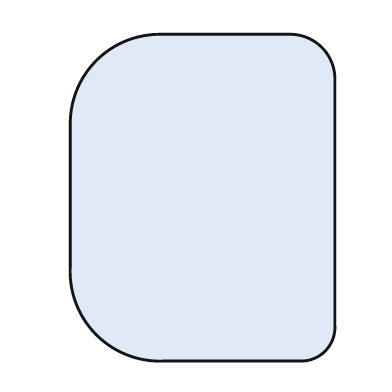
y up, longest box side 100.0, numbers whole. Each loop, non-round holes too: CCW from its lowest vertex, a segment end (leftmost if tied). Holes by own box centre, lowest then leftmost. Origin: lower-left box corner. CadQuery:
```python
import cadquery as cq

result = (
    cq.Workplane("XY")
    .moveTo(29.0, 0.0)
    .lineTo(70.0, 0.0)
    .threePointArc((78.0, 3.0), (81.0, 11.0))
    .lineTo(81.0, 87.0)
    .threePointArc((77.0, 96.0), (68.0, 100.0))
    .lineTo(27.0, 100.0)
    .threePointArc((8.0, 92.0), (0.0, 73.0))
    .lineTo(0.0, 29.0)
    .threePointArc((8.0, 8.0), (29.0, 0.0))
    .close()
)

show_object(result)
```